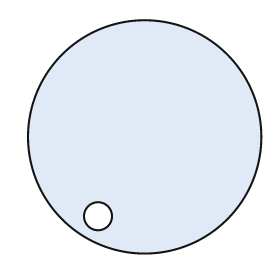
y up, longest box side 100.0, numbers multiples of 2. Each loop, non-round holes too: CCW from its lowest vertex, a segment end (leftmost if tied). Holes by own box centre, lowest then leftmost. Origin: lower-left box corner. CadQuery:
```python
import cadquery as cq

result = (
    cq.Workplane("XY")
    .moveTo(50.0, 50.0)
    .circle(50.0)
    .moveTo(30.0, 16.0)
    .circle(6.0)
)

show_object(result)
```